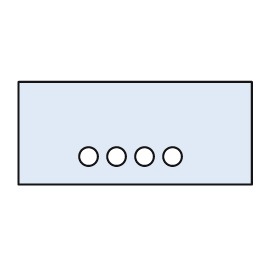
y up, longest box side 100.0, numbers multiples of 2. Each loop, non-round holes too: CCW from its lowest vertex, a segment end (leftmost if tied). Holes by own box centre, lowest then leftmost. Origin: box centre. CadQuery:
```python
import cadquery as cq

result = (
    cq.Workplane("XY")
    .moveTo(-50.0, -22.0)
    .lineTo(50.0, -22.0)
    .lineTo(50.0, 22.0)
    .lineTo(-50.0, 22.0)
    .close()
    .moveTo(-20.0, -10.0)
    .circle(4.0)
    .moveTo(-8.0, -10.0)
    .circle(4.0)
    .moveTo(4.0, -10.0)
    .circle(4.0)
    .moveTo(16.0, -10.0)
    .circle(4.0)
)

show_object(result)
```